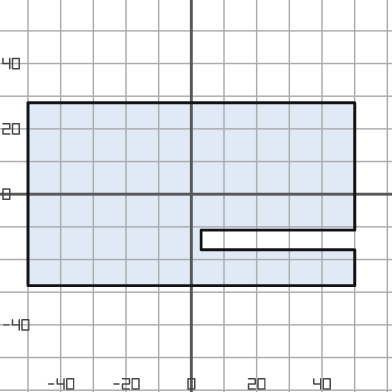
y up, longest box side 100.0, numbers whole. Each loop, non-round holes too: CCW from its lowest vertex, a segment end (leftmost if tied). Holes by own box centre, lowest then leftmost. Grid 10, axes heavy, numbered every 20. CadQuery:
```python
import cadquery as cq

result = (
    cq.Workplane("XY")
    .moveTo(-50.0, -28.0)
    .lineTo(50.0, -28.0)
    .lineTo(50.0, -17.0)
    .lineTo(3.0, -17.0)
    .lineTo(3.0, -11.0)
    .lineTo(50.0, -11.0)
    .lineTo(50.0, 28.0)
    .lineTo(-50.0, 28.0)
    .close()
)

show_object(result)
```